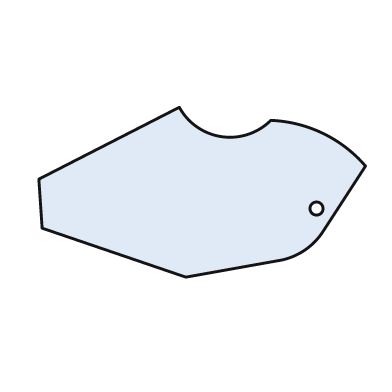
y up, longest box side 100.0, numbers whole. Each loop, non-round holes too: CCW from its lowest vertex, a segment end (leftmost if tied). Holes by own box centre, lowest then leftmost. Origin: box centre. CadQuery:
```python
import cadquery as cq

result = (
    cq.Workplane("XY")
    .moveTo(-5.0, -26.0)
    .lineTo(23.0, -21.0)
    .threePointArc((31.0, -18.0), (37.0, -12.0))
    .lineTo(50.0, 8.0)
    .threePointArc((37.0, 18.0), (21.0, 22.0))
    .threePointArc((6.0, 17.0), (-7.0, 26.0))
    .lineTo(-50.0, 4.0)
    .lineTo(-49.0, -11.0)
    .close()
    .moveTo(35.0, -5.0)
    .circle(2.0)
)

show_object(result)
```